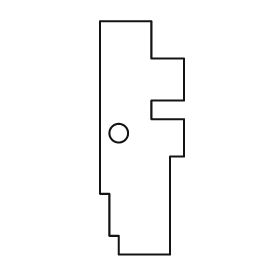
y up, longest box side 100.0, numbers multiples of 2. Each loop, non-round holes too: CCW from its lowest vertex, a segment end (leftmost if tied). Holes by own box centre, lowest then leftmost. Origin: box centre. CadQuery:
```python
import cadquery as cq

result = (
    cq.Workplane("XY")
    .moveTo(-10.0, -50.0)
    .lineTo(12.0, -50.0)
    .lineTo(12.0, -8.0)
    .lineTo(18.0, -8.0)
    .lineTo(18.0, 8.0)
    .lineTo(4.0, 8.0)
    .lineTo(4.0, 16.0)
    .lineTo(18.0, 16.0)
    .lineTo(18.0, 34.0)
    .lineTo(4.0, 34.0)
    .lineTo(4.0, 50.0)
    .lineTo(-18.0, 50.0)
    .lineTo(-18.0, -24.0)
    .lineTo(-14.0, -24.0)
    .lineTo(-14.0, -42.0)
    .lineTo(-10.0, -42.0)
    .close()
    .moveTo(-10.0, 2.0)
    .circle(4.0)
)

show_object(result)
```